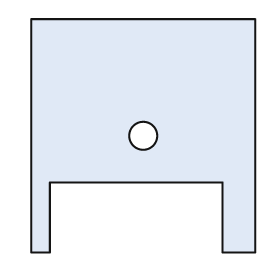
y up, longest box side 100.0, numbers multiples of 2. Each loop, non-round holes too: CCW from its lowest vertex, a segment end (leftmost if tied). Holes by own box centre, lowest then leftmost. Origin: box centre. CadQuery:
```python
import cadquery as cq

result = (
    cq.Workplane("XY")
    .moveTo(-48.0, -50.0)
    .lineTo(-40.0, -50.0)
    .lineTo(-40.0, -20.0)
    .lineTo(34.0, -20.0)
    .lineTo(34.0, -50.0)
    .lineTo(48.0, -50.0)
    .lineTo(48.0, 50.0)
    .lineTo(-48.0, 50.0)
    .close()
    .moveTo(0.0, 0.0)
    .circle(6.0)
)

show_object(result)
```